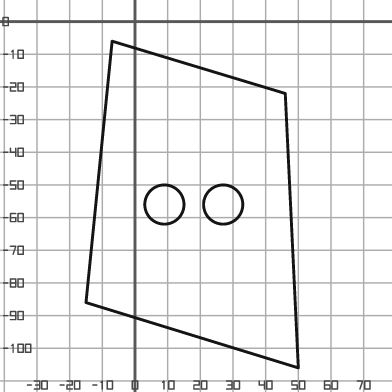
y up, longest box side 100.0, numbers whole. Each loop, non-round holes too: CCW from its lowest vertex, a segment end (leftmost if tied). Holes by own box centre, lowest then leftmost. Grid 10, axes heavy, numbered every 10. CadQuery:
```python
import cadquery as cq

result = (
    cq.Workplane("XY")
    .moveTo(50.0, -106.0)
    .lineTo(46.0, -22.0)
    .lineTo(-7.0, -6.0)
    .lineTo(-15.0, -86.0)
    .close()
    .moveTo(9.0, -56.0)
    .circle(6.0)
    .moveTo(27.0, -56.0)
    .circle(6.0)
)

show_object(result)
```